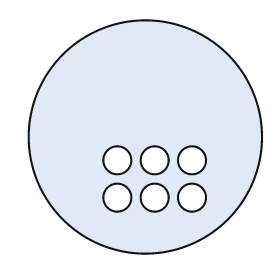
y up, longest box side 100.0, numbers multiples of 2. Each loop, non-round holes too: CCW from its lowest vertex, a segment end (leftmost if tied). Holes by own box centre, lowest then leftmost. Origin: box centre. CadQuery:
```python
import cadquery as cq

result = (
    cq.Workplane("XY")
    .moveTo(0.0, 0.0)
    .circle(50.0)
    .moveTo(-12.0, -26.0)
    .circle(6.0)
    .moveTo(4.0, -26.0)
    .circle(6.0)
    .moveTo(20.0, -26.0)
    .circle(6.0)
    .moveTo(-12.0, -10.0)
    .circle(6.0)
    .moveTo(4.0, -10.0)
    .circle(6.0)
    .moveTo(20.0, -10.0)
    .circle(6.0)
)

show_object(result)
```